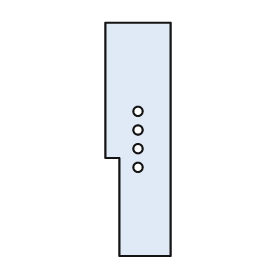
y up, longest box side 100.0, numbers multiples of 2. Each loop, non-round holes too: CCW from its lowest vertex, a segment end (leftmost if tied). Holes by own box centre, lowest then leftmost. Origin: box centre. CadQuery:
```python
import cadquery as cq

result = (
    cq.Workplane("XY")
    .moveTo(-8.0, -50.0)
    .lineTo(14.0, -50.0)
    .lineTo(14.0, 50.0)
    .lineTo(-14.0, 50.0)
    .lineTo(-14.0, -8.0)
    .lineTo(-8.0, -8.0)
    .close()
    .moveTo(0.0, -12.0)
    .circle(2.0)
    .moveTo(0.0, -4.0)
    .circle(2.0)
    .moveTo(0.0, 4.0)
    .circle(2.0)
    .moveTo(0.0, 12.0)
    .circle(2.0)
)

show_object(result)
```